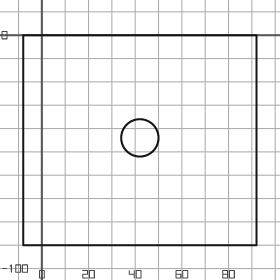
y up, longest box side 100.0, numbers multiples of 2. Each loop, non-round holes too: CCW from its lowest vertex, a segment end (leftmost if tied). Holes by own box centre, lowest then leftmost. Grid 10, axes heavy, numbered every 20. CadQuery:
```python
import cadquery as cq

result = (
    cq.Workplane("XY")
    .moveTo(-8.0, -90.0)
    .lineTo(92.0, -90.0)
    .lineTo(92.0, 0.0)
    .lineTo(-8.0, 0.0)
    .close()
    .moveTo(42.0, -44.0)
    .circle(8.0)
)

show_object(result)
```